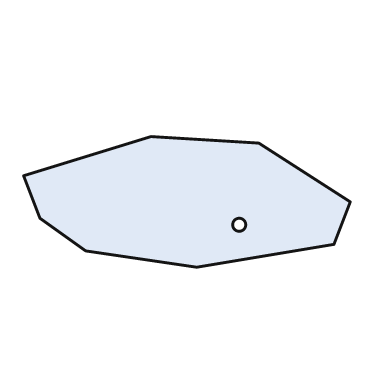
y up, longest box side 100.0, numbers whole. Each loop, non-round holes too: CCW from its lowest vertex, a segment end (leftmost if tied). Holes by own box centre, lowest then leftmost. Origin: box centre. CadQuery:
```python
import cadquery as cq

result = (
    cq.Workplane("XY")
    .moveTo(3.0, -20.0)
    .lineTo(45.0, -13.0)
    .lineTo(50.0, 0.0)
    .lineTo(22.0, 18.0)
    .lineTo(-11.0, 20.0)
    .lineTo(-50.0, 8.0)
    .lineTo(-45.0, -5.0)
    .lineTo(-31.0, -15.0)
    .close()
    .moveTo(16.0, -7.0)
    .circle(2.0)
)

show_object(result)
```